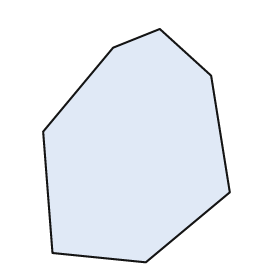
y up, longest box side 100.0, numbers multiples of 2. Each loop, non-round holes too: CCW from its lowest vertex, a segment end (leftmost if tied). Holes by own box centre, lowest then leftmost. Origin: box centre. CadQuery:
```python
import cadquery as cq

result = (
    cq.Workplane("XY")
    .moveTo(4.0, -50.0)
    .lineTo(40.0, -20.0)
    .lineTo(32.0, 30.0)
    .lineTo(10.0, 50.0)
    .lineTo(-10.0, 42.0)
    .lineTo(-40.0, 6.0)
    .lineTo(-36.0, -46.0)
    .close()
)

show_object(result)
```